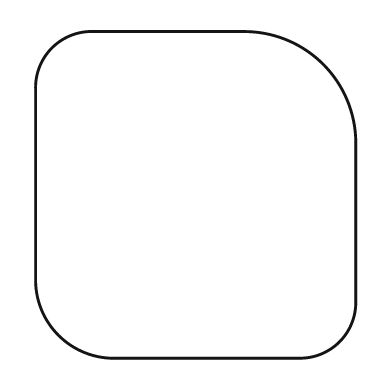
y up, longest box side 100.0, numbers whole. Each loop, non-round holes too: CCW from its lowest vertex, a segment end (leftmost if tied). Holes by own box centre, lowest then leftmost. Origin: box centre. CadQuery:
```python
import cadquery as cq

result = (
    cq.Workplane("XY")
    .moveTo(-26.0, -50.0)
    .lineTo(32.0, -50.0)
    .threePointArc((44.0, -45.0), (49.0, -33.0))
    .lineTo(49.0, 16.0)
    .threePointArc((39.0, 40.0), (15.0, 50.0))
    .lineTo(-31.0, 50.0)
    .threePointArc((-44.0, 45.0), (-49.0, 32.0))
    .lineTo(-49.0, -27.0)
    .threePointArc((-42.0, -43.0), (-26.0, -50.0))
    .close()
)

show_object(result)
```